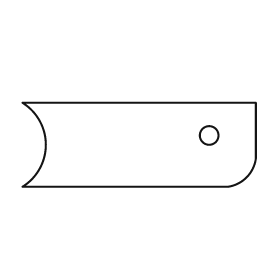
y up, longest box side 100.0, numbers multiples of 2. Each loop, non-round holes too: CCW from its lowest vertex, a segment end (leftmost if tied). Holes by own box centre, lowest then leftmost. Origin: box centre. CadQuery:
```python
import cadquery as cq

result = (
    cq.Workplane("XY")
    .moveTo(-50.0, -18.0)
    .lineTo(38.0, -18.0)
    .threePointArc((46.0, -14.0), (50.0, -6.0))
    .lineTo(50.0, 18.0)
    .lineTo(-50.0, 18.0)
    .threePointArc((-40.0, 0.0), (-50.0, -18.0))
    .close()
    .moveTo(30.0, 4.0)
    .circle(4.0)
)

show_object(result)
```